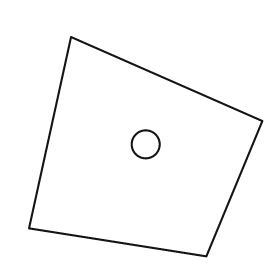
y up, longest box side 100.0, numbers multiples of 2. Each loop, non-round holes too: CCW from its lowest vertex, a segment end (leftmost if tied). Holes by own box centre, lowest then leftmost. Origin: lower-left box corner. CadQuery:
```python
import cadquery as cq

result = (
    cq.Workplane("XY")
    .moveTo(76.0, 0.0)
    .lineTo(100.0, 58.0)
    .lineTo(18.0, 94.0)
    .lineTo(0.0, 12.0)
    .close()
    .moveTo(50.0, 48.0)
    .circle(6.0)
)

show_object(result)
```